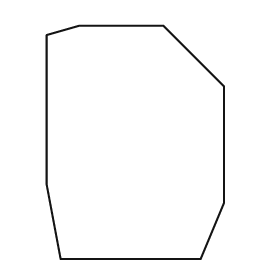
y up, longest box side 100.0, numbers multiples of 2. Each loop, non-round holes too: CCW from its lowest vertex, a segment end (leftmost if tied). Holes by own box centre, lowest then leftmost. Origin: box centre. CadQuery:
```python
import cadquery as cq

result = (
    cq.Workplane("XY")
    .moveTo(-32.0, -50.0)
    .lineTo(28.0, -50.0)
    .lineTo(38.0, -26.0)
    .lineTo(38.0, 24.0)
    .lineTo(12.0, 50.0)
    .lineTo(-24.0, 50.0)
    .lineTo(-38.0, 46.0)
    .lineTo(-38.0, -18.0)
    .close()
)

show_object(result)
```